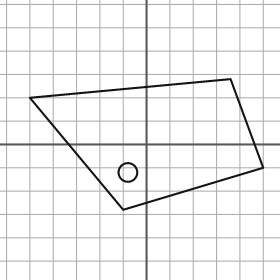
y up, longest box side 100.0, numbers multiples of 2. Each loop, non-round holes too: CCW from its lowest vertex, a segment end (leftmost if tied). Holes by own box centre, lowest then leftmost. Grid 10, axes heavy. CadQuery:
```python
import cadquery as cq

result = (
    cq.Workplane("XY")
    .moveTo(-10.0, -28.0)
    .lineTo(50.0, -10.0)
    .lineTo(36.0, 28.0)
    .lineTo(-50.0, 20.0)
    .close()
    .moveTo(-8.0, -12.0)
    .circle(4.0)
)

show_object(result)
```